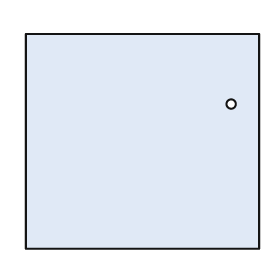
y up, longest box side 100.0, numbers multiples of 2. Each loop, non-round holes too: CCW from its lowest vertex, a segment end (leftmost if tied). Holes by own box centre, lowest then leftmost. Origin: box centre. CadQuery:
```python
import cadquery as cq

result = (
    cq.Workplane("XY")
    .moveTo(-50.0, -46.0)
    .lineTo(50.0, -46.0)
    .lineTo(50.0, 46.0)
    .lineTo(-50.0, 46.0)
    .close()
    .moveTo(38.0, 16.0)
    .circle(2.0)
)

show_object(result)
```